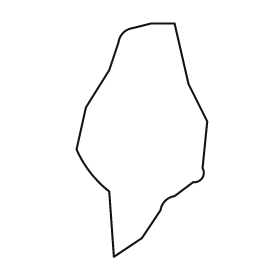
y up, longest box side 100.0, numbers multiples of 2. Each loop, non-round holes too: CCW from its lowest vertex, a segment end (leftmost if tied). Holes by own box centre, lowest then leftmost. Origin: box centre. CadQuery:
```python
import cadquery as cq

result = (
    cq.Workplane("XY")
    .moveTo(-12.0, -50.0)
    .lineTo(0.0, -42.0)
    .lineTo(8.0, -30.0)
    .threePointArc((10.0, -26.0), (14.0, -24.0))
    .lineTo(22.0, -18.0)
    .threePointArc((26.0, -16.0), (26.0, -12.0))
    .lineTo(28.0, 8.0)
    .lineTo(20.0, 24.0)
    .lineTo(14.0, 50.0)
    .lineTo(4.0, 50.0)
    .lineTo(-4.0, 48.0)
    .threePointArc((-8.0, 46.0), (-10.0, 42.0))
    .lineTo(-14.0, 30.0)
    .lineTo(-24.0, 14.0)
    .lineTo(-28.0, -4.0)
    .threePointArc((-22.0, -14.0), (-14.0, -22.0))
    .close()
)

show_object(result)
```